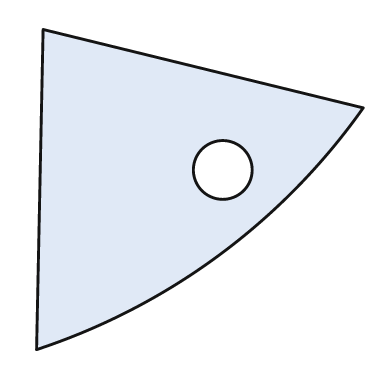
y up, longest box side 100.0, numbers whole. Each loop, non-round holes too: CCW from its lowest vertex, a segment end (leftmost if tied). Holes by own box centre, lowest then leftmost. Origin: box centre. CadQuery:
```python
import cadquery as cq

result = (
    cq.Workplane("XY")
    .moveTo(-50.0, -49.0)
    .threePointArc((6.0, -20.0), (50.0, 25.0))
    .lineTo(-48.0, 49.0)
    .close()
    .moveTo(7.0, 6.0)
    .circle(9.0)
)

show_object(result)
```